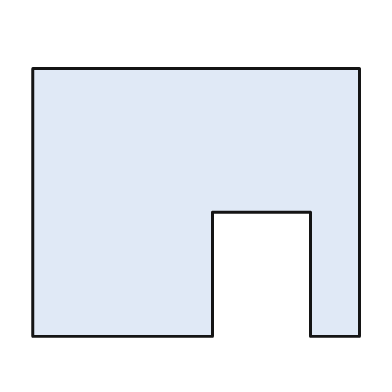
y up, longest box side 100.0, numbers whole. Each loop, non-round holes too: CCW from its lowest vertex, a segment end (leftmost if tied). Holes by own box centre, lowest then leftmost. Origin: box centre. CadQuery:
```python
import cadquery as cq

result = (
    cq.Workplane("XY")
    .moveTo(-50.0, -41.0)
    .lineTo(5.0, -41.0)
    .lineTo(5.0, -3.0)
    .lineTo(35.0, -3.0)
    .lineTo(35.0, -41.0)
    .lineTo(50.0, -41.0)
    .lineTo(50.0, 41.0)
    .lineTo(-50.0, 41.0)
    .close()
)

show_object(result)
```